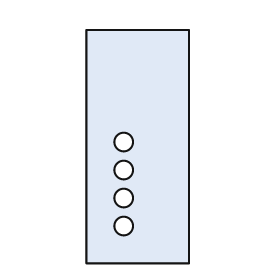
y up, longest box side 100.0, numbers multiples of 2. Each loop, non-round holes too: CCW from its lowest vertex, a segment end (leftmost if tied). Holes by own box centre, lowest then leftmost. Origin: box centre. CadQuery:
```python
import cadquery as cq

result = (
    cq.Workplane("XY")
    .moveTo(-22.0, -50.0)
    .lineTo(22.0, -50.0)
    .lineTo(22.0, 50.0)
    .lineTo(-22.0, 50.0)
    .close()
    .moveTo(-6.0, -34.0)
    .circle(4.0)
    .moveTo(-6.0, -22.0)
    .circle(4.0)
    .moveTo(-6.0, -10.0)
    .circle(4.0)
    .moveTo(-6.0, 2.0)
    .circle(4.0)
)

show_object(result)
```